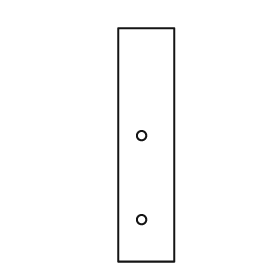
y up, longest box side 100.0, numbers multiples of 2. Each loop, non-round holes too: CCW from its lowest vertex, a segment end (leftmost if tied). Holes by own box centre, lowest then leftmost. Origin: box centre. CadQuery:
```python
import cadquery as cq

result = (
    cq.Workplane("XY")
    .moveTo(-12.0, -50.0)
    .lineTo(12.0, -50.0)
    .lineTo(12.0, 50.0)
    .lineTo(-12.0, 50.0)
    .close()
    .moveTo(-2.0, -32.0)
    .circle(2.0)
    .moveTo(-2.0, 4.0)
    .circle(2.0)
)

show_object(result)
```